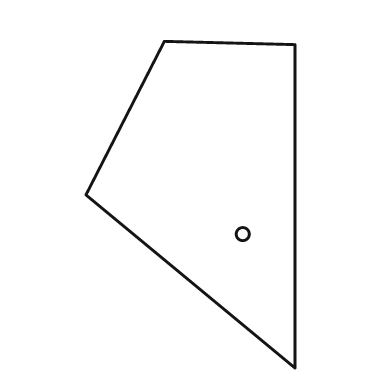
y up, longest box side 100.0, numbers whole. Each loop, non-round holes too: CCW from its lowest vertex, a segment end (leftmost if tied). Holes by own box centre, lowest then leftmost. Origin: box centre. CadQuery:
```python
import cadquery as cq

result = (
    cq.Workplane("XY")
    .moveTo(32.0, -50.0)
    .lineTo(32.0, 49.0)
    .lineTo(-8.0, 50.0)
    .lineTo(-32.0, 3.0)
    .close()
    .moveTo(16.0, -9.0)
    .circle(2.0)
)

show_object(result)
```